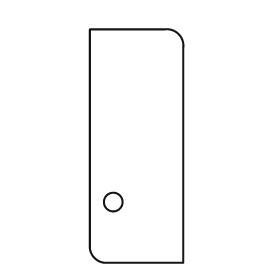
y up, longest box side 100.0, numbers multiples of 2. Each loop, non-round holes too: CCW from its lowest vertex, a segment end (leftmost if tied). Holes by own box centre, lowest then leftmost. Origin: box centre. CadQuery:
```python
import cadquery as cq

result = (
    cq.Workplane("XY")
    .moveTo(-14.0, -50.0)
    .lineTo(20.0, -50.0)
    .lineTo(20.0, 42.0)
    .threePointArc((18.0, 48.0), (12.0, 50.0))
    .lineTo(-20.0, 50.0)
    .lineTo(-20.0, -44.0)
    .threePointArc((-18.0, -48.0), (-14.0, -50.0))
    .close()
    .moveTo(-10.0, -24.0)
    .circle(4.0)
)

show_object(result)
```